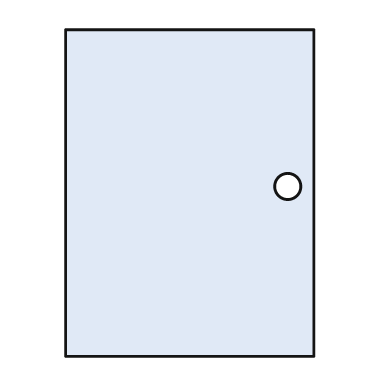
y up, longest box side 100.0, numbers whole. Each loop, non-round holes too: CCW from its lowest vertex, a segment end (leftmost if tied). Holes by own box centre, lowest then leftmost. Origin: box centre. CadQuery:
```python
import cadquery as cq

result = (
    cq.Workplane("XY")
    .moveTo(-38.0, -50.0)
    .lineTo(38.0, -50.0)
    .lineTo(38.0, 50.0)
    .lineTo(-38.0, 50.0)
    .close()
    .moveTo(30.0, 2.0)
    .circle(4.0)
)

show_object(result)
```